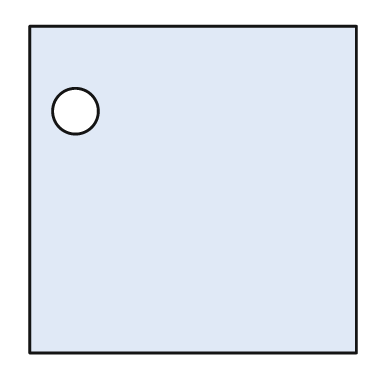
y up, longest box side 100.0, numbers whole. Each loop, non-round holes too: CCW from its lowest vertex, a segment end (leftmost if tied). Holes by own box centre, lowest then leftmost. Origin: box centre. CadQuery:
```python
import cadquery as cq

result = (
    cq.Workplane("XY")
    .moveTo(-50.0, -50.0)
    .lineTo(50.0, -50.0)
    .lineTo(50.0, 50.0)
    .lineTo(-50.0, 50.0)
    .close()
    .moveTo(-36.0, 24.0)
    .circle(7.0)
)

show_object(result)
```